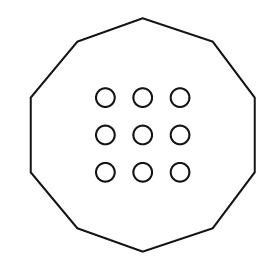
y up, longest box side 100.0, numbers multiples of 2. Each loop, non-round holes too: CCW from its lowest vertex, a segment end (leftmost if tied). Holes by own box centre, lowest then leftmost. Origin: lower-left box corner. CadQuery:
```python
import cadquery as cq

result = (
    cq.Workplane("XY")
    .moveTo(48.0, 0.0)
    .lineTo(78.0, 10.0)
    .lineTo(96.0, 34.0)
    .lineTo(96.0, 66.0)
    .lineTo(78.0, 90.0)
    .lineTo(48.0, 100.0)
    .lineTo(20.0, 90.0)
    .lineTo(0.0, 66.0)
    .lineTo(0.0, 34.0)
    .lineTo(20.0, 10.0)
    .close()
    .moveTo(32.0, 34.0)
    .circle(4.0)
    .moveTo(48.0, 34.0)
    .circle(4.0)
    .moveTo(64.0, 34.0)
    .circle(4.0)
    .moveTo(32.0, 50.0)
    .circle(4.0)
    .moveTo(48.0, 50.0)
    .circle(4.0)
    .moveTo(64.0, 50.0)
    .circle(4.0)
    .moveTo(32.0, 66.0)
    .circle(4.0)
    .moveTo(48.0, 66.0)
    .circle(4.0)
    .moveTo(64.0, 66.0)
    .circle(4.0)
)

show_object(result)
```